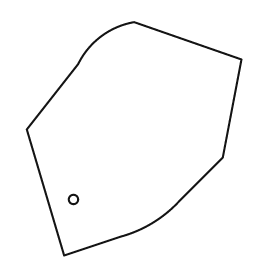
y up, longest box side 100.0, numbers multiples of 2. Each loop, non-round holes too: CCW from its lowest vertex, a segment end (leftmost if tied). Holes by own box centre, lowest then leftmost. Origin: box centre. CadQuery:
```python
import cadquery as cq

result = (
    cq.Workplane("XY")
    .moveTo(-30.0, -50.0)
    .lineTo(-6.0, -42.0)
    .threePointArc((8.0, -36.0), (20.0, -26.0))
    .lineTo(38.0, -8.0)
    .lineTo(46.0, 34.0)
    .lineTo(0.0, 50.0)
    .threePointArc((-14.0, 44.0), (-24.0, 32.0))
    .lineTo(-46.0, 4.0)
    .close()
    .moveTo(-26.0, -26.0)
    .circle(2.0)
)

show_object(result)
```